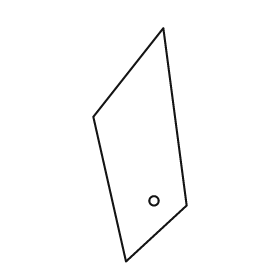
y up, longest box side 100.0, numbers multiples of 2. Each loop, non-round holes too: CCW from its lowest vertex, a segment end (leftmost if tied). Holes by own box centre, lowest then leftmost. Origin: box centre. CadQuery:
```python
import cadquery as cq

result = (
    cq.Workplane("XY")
    .moveTo(-6.0, -50.0)
    .lineTo(20.0, -26.0)
    .lineTo(10.0, 50.0)
    .lineTo(-20.0, 12.0)
    .close()
    .moveTo(6.0, -24.0)
    .circle(2.0)
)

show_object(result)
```